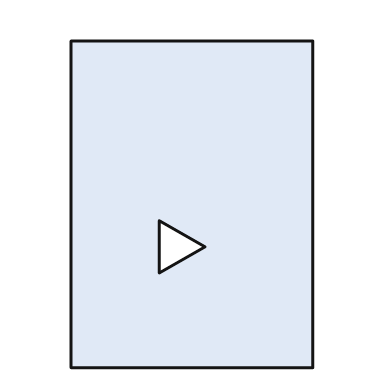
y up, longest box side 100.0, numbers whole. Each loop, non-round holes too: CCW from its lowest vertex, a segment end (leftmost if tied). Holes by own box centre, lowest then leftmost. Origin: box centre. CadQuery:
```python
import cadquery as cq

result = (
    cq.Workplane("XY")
    .moveTo(-37.0, -50.0)
    .lineTo(37.0, -50.0)
    .lineTo(37.0, 50.0)
    .lineTo(-37.0, 50.0)
    .close()
    .moveTo(-10.0, -21.0)
    .lineTo(4.0, -13.0)
    .lineTo(-10.0, -5.0)
    .close()
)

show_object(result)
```